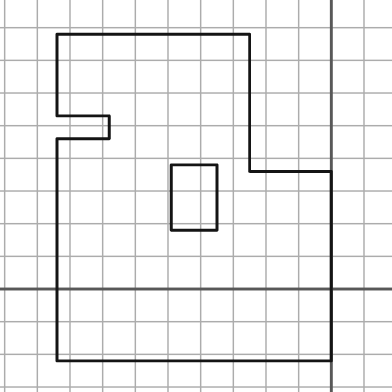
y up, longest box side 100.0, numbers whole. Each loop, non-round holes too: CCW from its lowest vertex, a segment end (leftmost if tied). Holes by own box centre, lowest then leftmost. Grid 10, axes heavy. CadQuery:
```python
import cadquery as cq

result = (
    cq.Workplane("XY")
    .moveTo(-84.0, -22.0)
    .lineTo(0.0, -22.0)
    .lineTo(0.0, 36.0)
    .lineTo(-25.0, 36.0)
    .lineTo(-25.0, 78.0)
    .lineTo(-84.0, 78.0)
    .lineTo(-84.0, 53.0)
    .lineTo(-68.0, 53.0)
    .lineTo(-68.0, 46.0)
    .lineTo(-84.0, 46.0)
    .close()
    .moveTo(-49.0, 18.0)
    .lineTo(-35.0, 18.0)
    .lineTo(-35.0, 38.0)
    .lineTo(-49.0, 38.0)
    .close()
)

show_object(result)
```